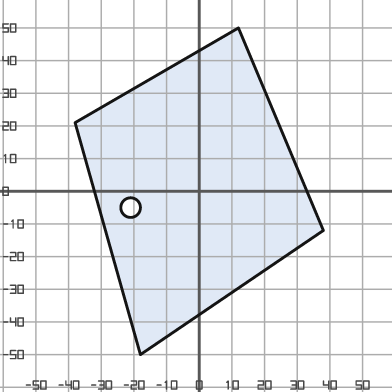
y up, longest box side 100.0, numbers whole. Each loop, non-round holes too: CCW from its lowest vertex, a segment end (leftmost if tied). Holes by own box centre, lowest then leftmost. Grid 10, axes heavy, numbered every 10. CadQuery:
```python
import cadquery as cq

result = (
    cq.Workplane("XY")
    .moveTo(-18.0, -50.0)
    .lineTo(38.0, -12.0)
    .lineTo(12.0, 50.0)
    .lineTo(-38.0, 21.0)
    .close()
    .moveTo(-21.0, -5.0)
    .circle(3.0)
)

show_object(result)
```